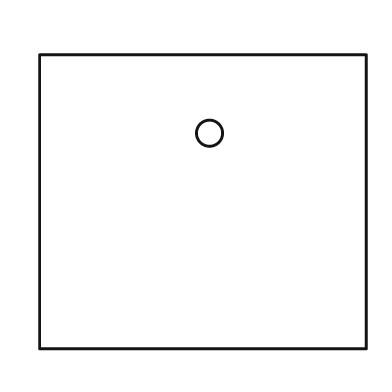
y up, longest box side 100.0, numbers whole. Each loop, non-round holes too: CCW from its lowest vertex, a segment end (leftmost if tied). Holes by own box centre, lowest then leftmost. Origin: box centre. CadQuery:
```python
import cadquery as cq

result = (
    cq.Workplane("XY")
    .moveTo(-50.0, -45.0)
    .lineTo(50.0, -45.0)
    .lineTo(50.0, 45.0)
    .lineTo(-50.0, 45.0)
    .close()
    .moveTo(2.0, 21.0)
    .circle(4.0)
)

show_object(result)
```